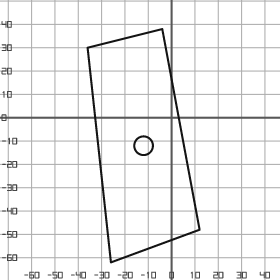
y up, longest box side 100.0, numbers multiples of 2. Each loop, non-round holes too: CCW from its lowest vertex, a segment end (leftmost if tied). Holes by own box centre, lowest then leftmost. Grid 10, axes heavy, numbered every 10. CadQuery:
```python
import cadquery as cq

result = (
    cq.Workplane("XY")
    .moveTo(-26.0, -62.0)
    .lineTo(12.0, -48.0)
    .lineTo(-4.0, 38.0)
    .lineTo(-36.0, 30.0)
    .close()
    .moveTo(-12.0, -12.0)
    .circle(4.0)
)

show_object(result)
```